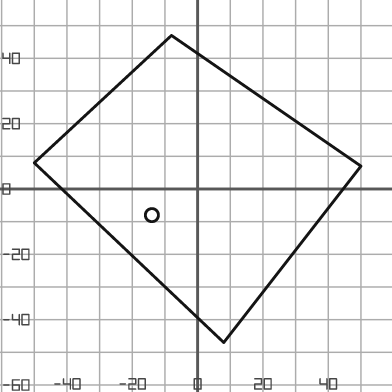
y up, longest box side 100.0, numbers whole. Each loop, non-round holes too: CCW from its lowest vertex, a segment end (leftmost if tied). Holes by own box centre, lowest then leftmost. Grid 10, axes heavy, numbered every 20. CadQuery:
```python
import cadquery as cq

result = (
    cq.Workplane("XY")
    .moveTo(8.0, -47.0)
    .lineTo(50.0, 7.0)
    .lineTo(-8.0, 47.0)
    .lineTo(-50.0, 8.0)
    .close()
    .moveTo(-14.0, -8.0)
    .circle(2.0)
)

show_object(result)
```